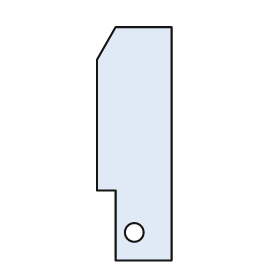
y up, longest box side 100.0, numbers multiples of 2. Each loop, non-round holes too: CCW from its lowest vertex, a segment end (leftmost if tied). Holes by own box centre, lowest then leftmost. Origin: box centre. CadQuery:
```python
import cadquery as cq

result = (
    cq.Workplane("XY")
    .moveTo(-8.0, -50.0)
    .lineTo(16.0, -50.0)
    .lineTo(16.0, 50.0)
    .lineTo(-8.0, 50.0)
    .lineTo(-16.0, 36.0)
    .lineTo(-16.0, -20.0)
    .lineTo(-8.0, -20.0)
    .close()
    .moveTo(0.0, -38.0)
    .circle(4.0)
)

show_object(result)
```